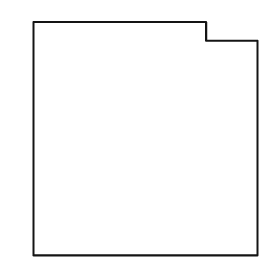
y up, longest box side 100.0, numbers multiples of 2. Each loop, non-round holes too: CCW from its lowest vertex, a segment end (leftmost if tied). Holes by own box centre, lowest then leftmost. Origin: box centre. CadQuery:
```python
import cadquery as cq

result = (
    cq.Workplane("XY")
    .moveTo(-48.0, -50.0)
    .lineTo(48.0, -50.0)
    .lineTo(48.0, 42.0)
    .lineTo(26.0, 42.0)
    .lineTo(26.0, 50.0)
    .lineTo(-48.0, 50.0)
    .close()
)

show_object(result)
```